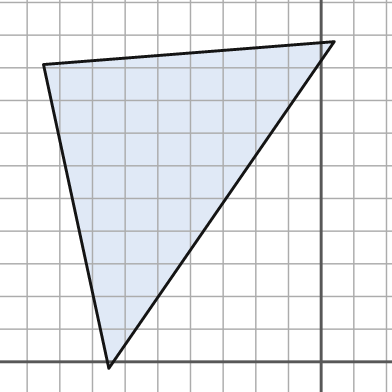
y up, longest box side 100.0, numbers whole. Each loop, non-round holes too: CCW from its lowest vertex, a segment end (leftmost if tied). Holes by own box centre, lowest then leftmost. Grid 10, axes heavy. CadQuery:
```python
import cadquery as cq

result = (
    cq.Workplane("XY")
    .moveTo(-65.0, -2.0)
    .lineTo(4.0, 98.0)
    .lineTo(-85.0, 91.0)
    .close()
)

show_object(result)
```